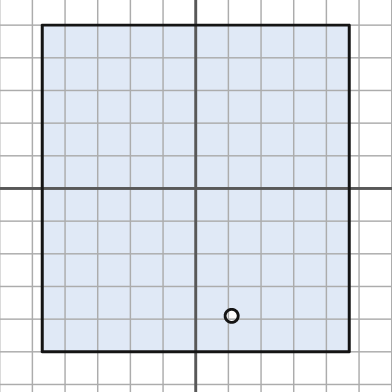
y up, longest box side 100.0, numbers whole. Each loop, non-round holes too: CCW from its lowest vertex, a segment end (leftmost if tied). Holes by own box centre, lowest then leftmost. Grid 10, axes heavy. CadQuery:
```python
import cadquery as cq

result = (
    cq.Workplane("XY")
    .moveTo(-47.0, -50.0)
    .lineTo(47.0, -50.0)
    .lineTo(47.0, 50.0)
    .lineTo(-47.0, 50.0)
    .close()
    .moveTo(11.0, -39.0)
    .circle(2.0)
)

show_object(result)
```